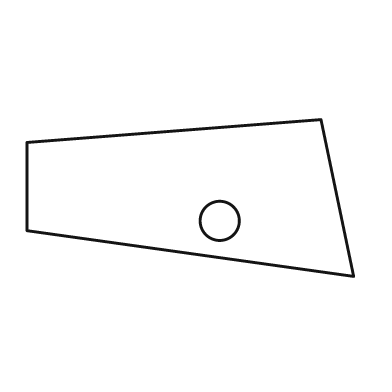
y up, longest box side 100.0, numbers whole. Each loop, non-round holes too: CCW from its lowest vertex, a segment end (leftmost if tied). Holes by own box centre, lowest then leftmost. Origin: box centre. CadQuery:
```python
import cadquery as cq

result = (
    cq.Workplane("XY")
    .moveTo(50.0, -24.0)
    .lineTo(40.0, 24.0)
    .lineTo(-50.0, 17.0)
    .lineTo(-50.0, -10.0)
    .close()
    .moveTo(9.0, -7.0)
    .circle(6.0)
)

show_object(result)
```